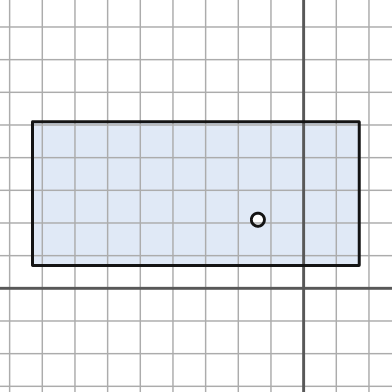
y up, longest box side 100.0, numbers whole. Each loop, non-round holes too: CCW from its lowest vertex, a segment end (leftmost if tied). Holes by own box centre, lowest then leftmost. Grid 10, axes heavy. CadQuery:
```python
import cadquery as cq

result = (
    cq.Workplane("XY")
    .moveTo(-83.0, 7.0)
    .lineTo(17.0, 7.0)
    .lineTo(17.0, 51.0)
    .lineTo(-83.0, 51.0)
    .close()
    .moveTo(-14.0, 21.0)
    .circle(2.0)
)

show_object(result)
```